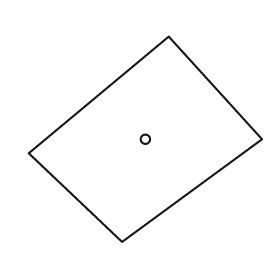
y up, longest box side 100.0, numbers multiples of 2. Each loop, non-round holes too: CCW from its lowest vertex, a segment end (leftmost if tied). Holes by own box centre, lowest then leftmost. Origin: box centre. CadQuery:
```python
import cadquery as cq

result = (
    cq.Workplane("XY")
    .moveTo(-10.0, -44.0)
    .lineTo(50.0, 0.0)
    .lineTo(10.0, 44.0)
    .lineTo(-50.0, -6.0)
    .close()
    .moveTo(0.0, 0.0)
    .circle(2.0)
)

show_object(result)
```